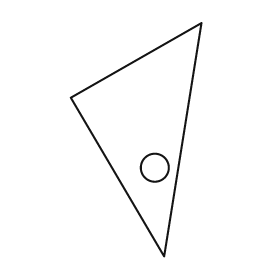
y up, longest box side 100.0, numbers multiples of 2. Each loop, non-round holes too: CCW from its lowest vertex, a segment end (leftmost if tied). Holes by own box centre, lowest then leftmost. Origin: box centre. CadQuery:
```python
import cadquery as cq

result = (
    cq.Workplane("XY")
    .moveTo(12.0, -50.0)
    .lineTo(28.0, 50.0)
    .lineTo(-28.0, 18.0)
    .close()
    .moveTo(8.0, -12.0)
    .circle(6.0)
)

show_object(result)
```